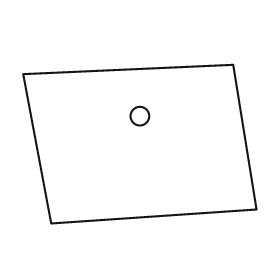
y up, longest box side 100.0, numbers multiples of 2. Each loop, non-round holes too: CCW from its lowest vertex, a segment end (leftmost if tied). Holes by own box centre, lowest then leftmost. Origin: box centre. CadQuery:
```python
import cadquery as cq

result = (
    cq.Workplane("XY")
    .moveTo(-38.0, -34.0)
    .lineTo(50.0, -28.0)
    .lineTo(40.0, 34.0)
    .lineTo(-50.0, 30.0)
    .close()
    .moveTo(0.0, 12.0)
    .circle(4.0)
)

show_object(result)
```